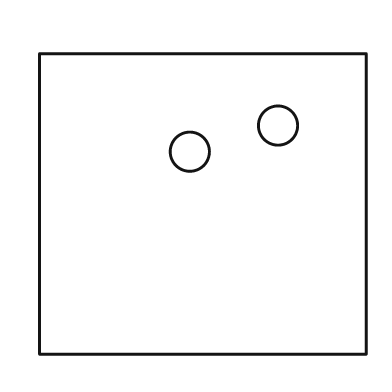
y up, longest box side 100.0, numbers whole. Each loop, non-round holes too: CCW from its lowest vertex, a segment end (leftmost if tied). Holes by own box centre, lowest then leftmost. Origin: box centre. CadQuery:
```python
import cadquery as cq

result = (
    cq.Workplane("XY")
    .moveTo(-50.0, -46.0)
    .lineTo(50.0, -46.0)
    .lineTo(50.0, 46.0)
    .lineTo(-50.0, 46.0)
    .close()
    .moveTo(-4.0, 16.0)
    .circle(6.0)
    .moveTo(23.0, 24.0)
    .circle(6.0)
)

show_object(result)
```